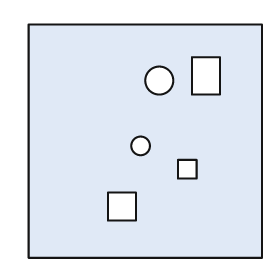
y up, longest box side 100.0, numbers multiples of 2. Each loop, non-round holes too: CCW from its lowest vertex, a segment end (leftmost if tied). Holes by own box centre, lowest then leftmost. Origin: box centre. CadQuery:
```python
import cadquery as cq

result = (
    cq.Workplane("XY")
    .moveTo(-50.0, -50.0)
    .lineTo(50.0, -50.0)
    .lineTo(50.0, 50.0)
    .lineTo(-50.0, 50.0)
    .close()
    .moveTo(-16.0, -34.0)
    .lineTo(-4.0, -34.0)
    .lineTo(-4.0, -22.0)
    .lineTo(-16.0, -22.0)
    .close()
    .moveTo(14.0, -16.0)
    .lineTo(22.0, -16.0)
    .lineTo(22.0, -8.0)
    .lineTo(14.0, -8.0)
    .close()
    .moveTo(-2.0, -2.0)
    .circle(4.0)
    .moveTo(6.0, 26.0)
    .circle(6.0)
    .moveTo(20.0, 20.0)
    .lineTo(32.0, 20.0)
    .lineTo(32.0, 36.0)
    .lineTo(20.0, 36.0)
    .close()
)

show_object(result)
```